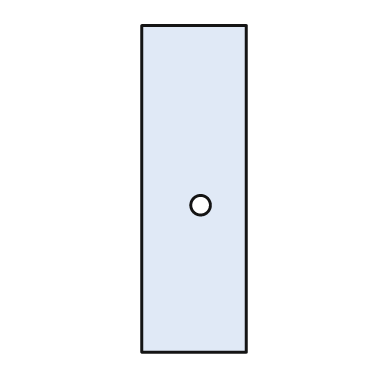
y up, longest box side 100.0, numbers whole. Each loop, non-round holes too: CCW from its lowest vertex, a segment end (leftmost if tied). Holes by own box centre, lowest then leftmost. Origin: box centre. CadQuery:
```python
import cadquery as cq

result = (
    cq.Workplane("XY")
    .moveTo(-16.0, -50.0)
    .lineTo(16.0, -50.0)
    .lineTo(16.0, 50.0)
    .lineTo(-16.0, 50.0)
    .close()
    .moveTo(2.0, -5.0)
    .circle(3.0)
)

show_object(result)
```